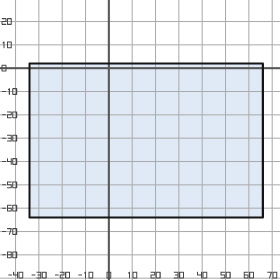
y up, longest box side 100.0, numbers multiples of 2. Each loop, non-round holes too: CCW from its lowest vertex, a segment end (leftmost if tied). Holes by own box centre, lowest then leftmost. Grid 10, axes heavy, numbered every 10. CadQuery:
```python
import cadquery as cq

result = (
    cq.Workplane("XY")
    .moveTo(-34.0, -64.0)
    .lineTo(66.0, -64.0)
    .lineTo(66.0, 2.0)
    .lineTo(-34.0, 2.0)
    .close()
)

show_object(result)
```